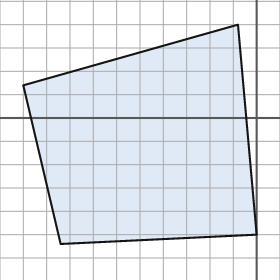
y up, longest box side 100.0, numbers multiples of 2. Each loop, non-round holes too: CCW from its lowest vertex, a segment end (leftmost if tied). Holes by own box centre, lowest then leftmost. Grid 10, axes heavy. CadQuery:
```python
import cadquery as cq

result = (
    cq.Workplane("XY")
    .moveTo(-84.0, -54.0)
    .lineTo(0.0, -50.0)
    .lineTo(-8.0, 40.0)
    .lineTo(-100.0, 14.0)
    .close()
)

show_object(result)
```